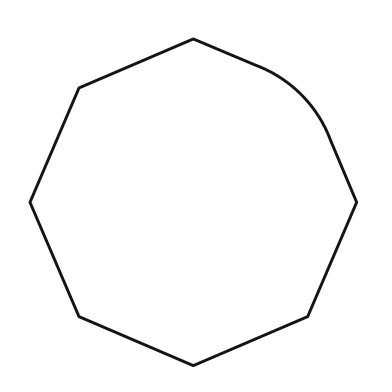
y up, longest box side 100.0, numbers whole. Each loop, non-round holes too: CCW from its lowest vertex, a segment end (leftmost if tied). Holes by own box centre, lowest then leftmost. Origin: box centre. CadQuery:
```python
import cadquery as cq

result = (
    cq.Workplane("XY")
    .moveTo(0.0, -50.0)
    .lineTo(35.0, -35.0)
    .lineTo(50.0, 0.0)
    .lineTo(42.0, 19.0)
    .threePointArc((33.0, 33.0), (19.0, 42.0))
    .lineTo(0.0, 50.0)
    .lineTo(-35.0, 35.0)
    .lineTo(-50.0, 0.0)
    .lineTo(-35.0, -35.0)
    .close()
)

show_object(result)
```